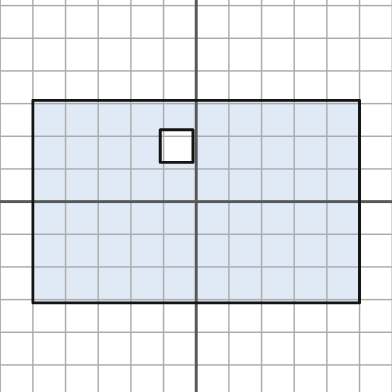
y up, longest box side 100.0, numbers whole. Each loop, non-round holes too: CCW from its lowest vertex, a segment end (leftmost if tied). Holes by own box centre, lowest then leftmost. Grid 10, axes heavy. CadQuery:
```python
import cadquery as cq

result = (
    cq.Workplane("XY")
    .moveTo(-50.0, -31.0)
    .lineTo(50.0, -31.0)
    .lineTo(50.0, 31.0)
    .lineTo(-50.0, 31.0)
    .close()
    .moveTo(-11.0, 12.0)
    .lineTo(-1.0, 12.0)
    .lineTo(-1.0, 22.0)
    .lineTo(-11.0, 22.0)
    .close()
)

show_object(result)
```